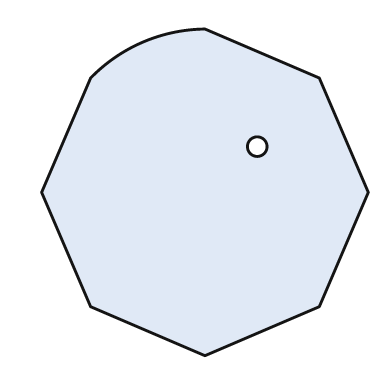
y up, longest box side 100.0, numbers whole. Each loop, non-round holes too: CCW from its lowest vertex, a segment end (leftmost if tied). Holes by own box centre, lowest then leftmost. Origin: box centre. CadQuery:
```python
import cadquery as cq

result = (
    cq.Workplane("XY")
    .moveTo(0.0, -50.0)
    .lineTo(35.0, -35.0)
    .lineTo(50.0, 0.0)
    .lineTo(35.0, 35.0)
    .lineTo(0.0, 50.0)
    .threePointArc((-19.0, 46.0), (-35.0, 35.0))
    .lineTo(-50.0, 0.0)
    .lineTo(-35.0, -35.0)
    .close()
    .moveTo(16.0, 14.0)
    .circle(3.0)
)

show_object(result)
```